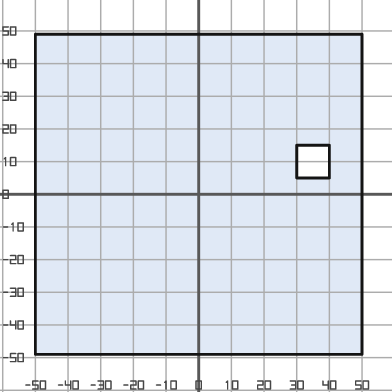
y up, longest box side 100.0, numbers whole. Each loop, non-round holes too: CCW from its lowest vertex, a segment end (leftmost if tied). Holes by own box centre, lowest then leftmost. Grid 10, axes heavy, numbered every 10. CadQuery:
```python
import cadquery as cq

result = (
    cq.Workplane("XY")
    .moveTo(-50.0, -49.0)
    .lineTo(50.0, -49.0)
    .lineTo(50.0, 49.0)
    .lineTo(-50.0, 49.0)
    .close()
    .moveTo(30.0, 5.0)
    .lineTo(40.0, 5.0)
    .lineTo(40.0, 15.0)
    .lineTo(30.0, 15.0)
    .close()
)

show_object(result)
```